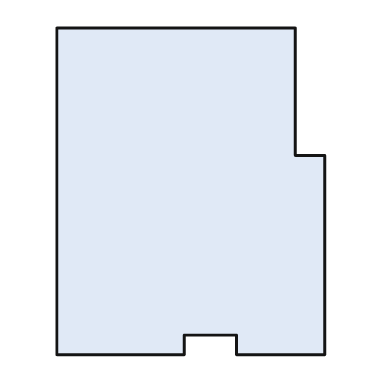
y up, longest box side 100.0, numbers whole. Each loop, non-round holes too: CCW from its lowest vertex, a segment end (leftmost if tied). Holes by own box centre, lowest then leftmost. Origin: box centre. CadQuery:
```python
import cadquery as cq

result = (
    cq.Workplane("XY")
    .moveTo(-41.0, -50.0)
    .lineTo(-2.0, -50.0)
    .lineTo(-2.0, -44.0)
    .lineTo(14.0, -44.0)
    .lineTo(14.0, -50.0)
    .lineTo(41.0, -50.0)
    .lineTo(41.0, 11.0)
    .lineTo(32.0, 11.0)
    .lineTo(32.0, 50.0)
    .lineTo(-41.0, 50.0)
    .close()
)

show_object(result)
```